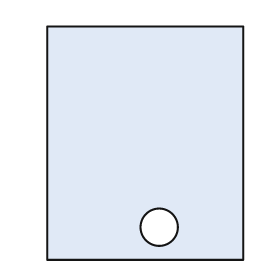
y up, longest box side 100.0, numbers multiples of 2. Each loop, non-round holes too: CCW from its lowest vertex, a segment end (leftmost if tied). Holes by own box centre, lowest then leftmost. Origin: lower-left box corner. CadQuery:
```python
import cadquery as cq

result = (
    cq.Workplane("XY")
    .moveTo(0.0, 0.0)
    .lineTo(84.0, 0.0)
    .lineTo(84.0, 100.0)
    .lineTo(0.0, 100.0)
    .close()
    .moveTo(48.0, 14.0)
    .circle(8.0)
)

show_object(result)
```